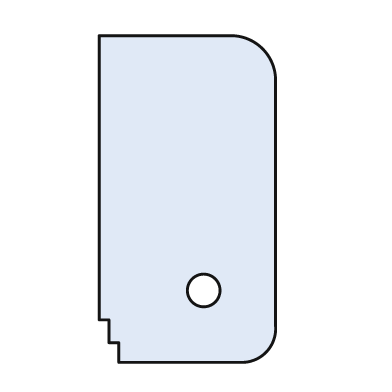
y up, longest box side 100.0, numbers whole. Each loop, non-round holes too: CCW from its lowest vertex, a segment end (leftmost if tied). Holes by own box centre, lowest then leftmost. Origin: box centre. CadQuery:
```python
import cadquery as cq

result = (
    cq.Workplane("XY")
    .moveTo(-21.0, -50.0)
    .lineTo(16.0, -50.0)
    .threePointArc((24.0, -47.0), (27.0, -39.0))
    .lineTo(27.0, 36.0)
    .threePointArc((23.0, 46.0), (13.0, 50.0))
    .lineTo(-27.0, 50.0)
    .lineTo(-27.0, -37.0)
    .lineTo(-24.0, -37.0)
    .lineTo(-24.0, -44.0)
    .lineTo(-21.0, -44.0)
    .close()
    .moveTo(5.0, -28.0)
    .circle(5.0)
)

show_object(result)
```